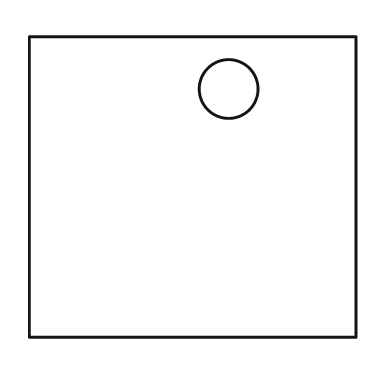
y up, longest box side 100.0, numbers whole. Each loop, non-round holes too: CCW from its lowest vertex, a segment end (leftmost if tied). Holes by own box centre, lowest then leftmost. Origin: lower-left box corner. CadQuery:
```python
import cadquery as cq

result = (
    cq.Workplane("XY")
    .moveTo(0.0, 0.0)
    .lineTo(100.0, 0.0)
    .lineTo(100.0, 92.0)
    .lineTo(0.0, 92.0)
    .close()
    .moveTo(61.0, 76.0)
    .circle(9.0)
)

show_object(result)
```